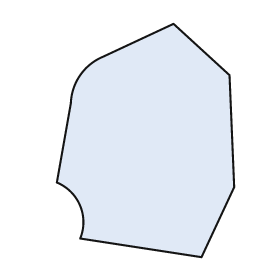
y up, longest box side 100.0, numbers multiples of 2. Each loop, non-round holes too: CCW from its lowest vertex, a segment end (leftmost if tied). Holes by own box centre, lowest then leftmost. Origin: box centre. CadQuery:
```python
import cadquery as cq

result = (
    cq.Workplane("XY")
    .moveTo(24.0, -50.0)
    .lineTo(38.0, -20.0)
    .lineTo(36.0, 28.0)
    .lineTo(12.0, 50.0)
    .lineTo(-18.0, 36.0)
    .threePointArc((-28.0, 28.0), (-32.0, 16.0))
    .lineTo(-38.0, -18.0)
    .threePointArc((-28.0, -28.0), (-28.0, -42.0))
    .close()
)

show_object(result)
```